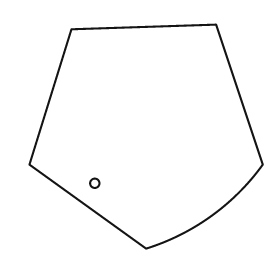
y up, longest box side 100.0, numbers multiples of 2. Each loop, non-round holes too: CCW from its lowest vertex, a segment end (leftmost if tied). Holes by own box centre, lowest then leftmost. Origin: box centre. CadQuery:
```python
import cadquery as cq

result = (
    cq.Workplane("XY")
    .moveTo(0.0, -48.0)
    .threePointArc((28.0, -34.0), (50.0, -12.0))
    .lineTo(30.0, 48.0)
    .lineTo(-32.0, 46.0)
    .lineTo(-50.0, -12.0)
    .close()
    .moveTo(-22.0, -20.0)
    .circle(2.0)
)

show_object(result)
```